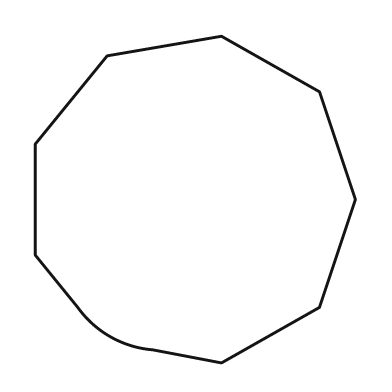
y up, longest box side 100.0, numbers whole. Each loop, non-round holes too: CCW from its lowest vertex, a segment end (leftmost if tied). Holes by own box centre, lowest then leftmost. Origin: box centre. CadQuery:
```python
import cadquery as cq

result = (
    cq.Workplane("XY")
    .moveTo(8.0, -50.0)
    .lineTo(38.0, -33.0)
    .lineTo(49.0, 0.0)
    .lineTo(38.0, 33.0)
    .lineTo(8.0, 50.0)
    .lineTo(-27.0, 44.0)
    .lineTo(-49.0, 17.0)
    .lineTo(-49.0, -17.0)
    .lineTo(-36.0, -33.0)
    .threePointArc((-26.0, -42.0), (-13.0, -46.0))
    .close()
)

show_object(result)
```